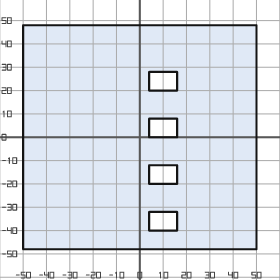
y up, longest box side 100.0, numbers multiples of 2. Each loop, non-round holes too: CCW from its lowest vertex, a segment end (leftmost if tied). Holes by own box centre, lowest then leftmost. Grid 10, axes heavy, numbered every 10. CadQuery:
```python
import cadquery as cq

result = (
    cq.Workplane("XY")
    .moveTo(-50.0, -48.0)
    .lineTo(50.0, -48.0)
    .lineTo(50.0, 48.0)
    .lineTo(-50.0, 48.0)
    .close()
    .moveTo(4.0, -40.0)
    .lineTo(16.0, -40.0)
    .lineTo(16.0, -32.0)
    .lineTo(4.0, -32.0)
    .close()
    .moveTo(4.0, -20.0)
    .lineTo(16.0, -20.0)
    .lineTo(16.0, -12.0)
    .lineTo(4.0, -12.0)
    .close()
    .moveTo(4.0, 0.0)
    .lineTo(16.0, 0.0)
    .lineTo(16.0, 8.0)
    .lineTo(4.0, 8.0)
    .close()
    .moveTo(4.0, 20.0)
    .lineTo(16.0, 20.0)
    .lineTo(16.0, 28.0)
    .lineTo(4.0, 28.0)
    .close()
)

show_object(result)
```